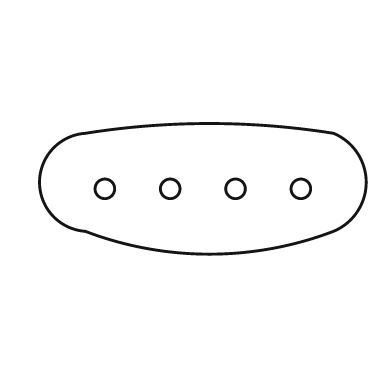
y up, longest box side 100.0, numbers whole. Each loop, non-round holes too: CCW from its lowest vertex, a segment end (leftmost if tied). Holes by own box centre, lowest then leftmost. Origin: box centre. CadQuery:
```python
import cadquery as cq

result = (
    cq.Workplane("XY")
    .moveTo(-36.0, -13.0)
    .threePointArc((2.0, -20.0), (40.0, -13.0))
    .threePointArc((50.0, 2.0), (40.0, 17.0))
    .threePointArc((2.0, 20.0), (-36.0, 17.0))
    .threePointArc((-50.0, 2.0), (-36.0, -13.0))
    .close()
    .moveTo(-30.0, 0.0)
    .circle(3.0)
    .moveTo(-10.0, 0.0)
    .circle(3.0)
    .moveTo(10.0, 0.0)
    .circle(3.0)
    .moveTo(30.0, 0.0)
    .circle(3.0)
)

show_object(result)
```